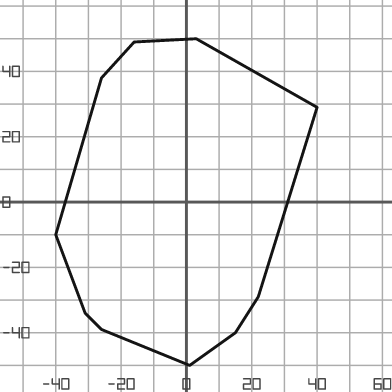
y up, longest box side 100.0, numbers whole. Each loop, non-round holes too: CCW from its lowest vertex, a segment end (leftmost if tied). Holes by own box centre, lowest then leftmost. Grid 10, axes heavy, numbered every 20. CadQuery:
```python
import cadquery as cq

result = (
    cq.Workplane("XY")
    .moveTo(1.0, -50.0)
    .lineTo(15.0, -40.0)
    .lineTo(22.0, -29.0)
    .lineTo(40.0, 29.0)
    .lineTo(3.0, 50.0)
    .lineTo(-16.0, 49.0)
    .lineTo(-26.0, 38.0)
    .lineTo(-40.0, -10.0)
    .lineTo(-31.0, -34.0)
    .lineTo(-26.0, -39.0)
    .close()
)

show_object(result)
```